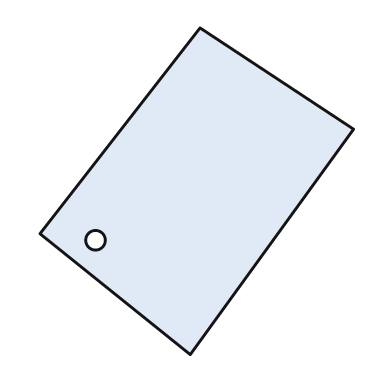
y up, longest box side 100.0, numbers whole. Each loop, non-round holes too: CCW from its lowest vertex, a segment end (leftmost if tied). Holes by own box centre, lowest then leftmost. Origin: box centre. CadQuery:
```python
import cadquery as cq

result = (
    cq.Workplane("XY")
    .moveTo(-2.0, -50.0)
    .lineTo(48.0, 19.0)
    .lineTo(1.0, 50.0)
    .lineTo(-48.0, -13.0)
    .close()
    .moveTo(-31.0, -15.0)
    .circle(3.0)
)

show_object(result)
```